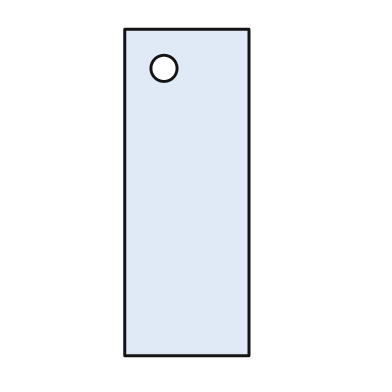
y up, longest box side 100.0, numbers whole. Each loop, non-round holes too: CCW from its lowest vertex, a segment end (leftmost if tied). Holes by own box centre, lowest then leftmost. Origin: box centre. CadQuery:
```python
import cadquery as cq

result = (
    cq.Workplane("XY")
    .moveTo(-19.0, -50.0)
    .lineTo(19.0, -50.0)
    .lineTo(19.0, 50.0)
    .lineTo(-19.0, 50.0)
    .close()
    .moveTo(-7.0, 38.0)
    .circle(4.0)
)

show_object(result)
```